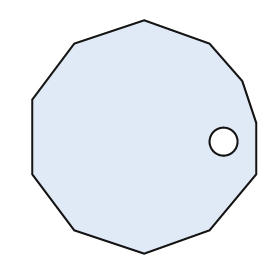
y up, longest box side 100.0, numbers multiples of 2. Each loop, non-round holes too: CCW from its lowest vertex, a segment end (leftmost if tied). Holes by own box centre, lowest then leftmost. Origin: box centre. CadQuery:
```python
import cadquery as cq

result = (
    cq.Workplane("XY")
    .moveTo(0.0, -50.0)
    .lineTo(28.0, -40.0)
    .lineTo(48.0, -16.0)
    .lineTo(48.0, 6.0)
    .lineTo(42.0, 24.0)
    .lineTo(28.0, 40.0)
    .lineTo(0.0, 50.0)
    .lineTo(-30.0, 40.0)
    .lineTo(-48.0, 16.0)
    .lineTo(-48.0, -16.0)
    .lineTo(-30.0, -40.0)
    .close()
    .moveTo(34.0, -2.0)
    .circle(6.0)
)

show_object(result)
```